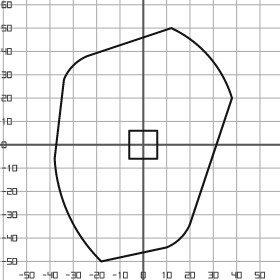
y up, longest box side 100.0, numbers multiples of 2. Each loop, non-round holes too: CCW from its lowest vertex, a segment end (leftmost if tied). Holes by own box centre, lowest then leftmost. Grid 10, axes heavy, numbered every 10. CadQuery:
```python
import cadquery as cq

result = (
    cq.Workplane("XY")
    .moveTo(-18.0, -50.0)
    .lineTo(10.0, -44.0)
    .threePointArc((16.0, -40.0), (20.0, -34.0))
    .lineTo(38.0, 20.0)
    .threePointArc((28.0, 38.0), (12.0, 50.0))
    .lineTo(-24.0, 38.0)
    .threePointArc((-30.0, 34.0), (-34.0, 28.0))
    .lineTo(-38.0, -6.0)
    .threePointArc((-32.0, -30.0), (-18.0, -50.0))
    .close()
    .moveTo(-6.0, -6.0)
    .lineTo(6.0, -6.0)
    .lineTo(6.0, 6.0)
    .lineTo(-6.0, 6.0)
    .close()
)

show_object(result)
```